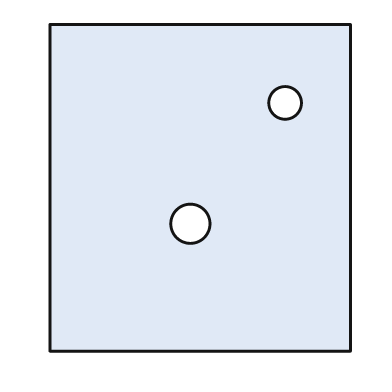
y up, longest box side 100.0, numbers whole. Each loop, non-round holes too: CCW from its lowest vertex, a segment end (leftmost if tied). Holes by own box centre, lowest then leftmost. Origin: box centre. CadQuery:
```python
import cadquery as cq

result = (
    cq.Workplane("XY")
    .moveTo(-46.0, -50.0)
    .lineTo(46.0, -50.0)
    .lineTo(46.0, 50.0)
    .lineTo(-46.0, 50.0)
    .close()
    .moveTo(-3.0, -11.0)
    .circle(6.0)
    .moveTo(26.0, 26.0)
    .circle(5.0)
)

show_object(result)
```